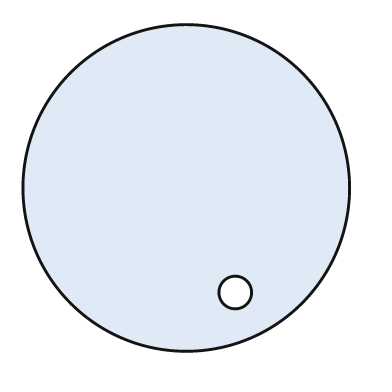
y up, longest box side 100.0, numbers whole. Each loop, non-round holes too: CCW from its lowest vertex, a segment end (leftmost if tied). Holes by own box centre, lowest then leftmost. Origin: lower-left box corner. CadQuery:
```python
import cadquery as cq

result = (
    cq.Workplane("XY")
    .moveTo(50.0, 50.0)
    .circle(50.0)
    .moveTo(65.0, 18.0)
    .circle(5.0)
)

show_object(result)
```